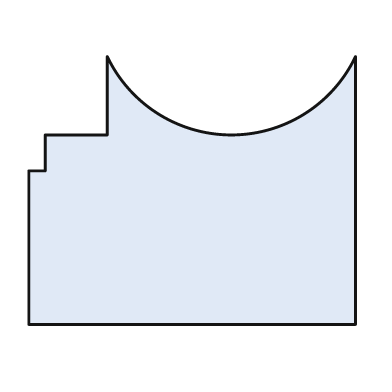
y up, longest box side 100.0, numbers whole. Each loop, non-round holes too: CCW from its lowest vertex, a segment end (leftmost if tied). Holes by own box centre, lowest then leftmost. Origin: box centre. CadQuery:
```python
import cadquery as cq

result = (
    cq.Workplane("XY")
    .moveTo(-50.0, -41.0)
    .lineTo(50.0, -41.0)
    .lineTo(50.0, 41.0)
    .threePointArc((12.0, 17.0), (-26.0, 41.0))
    .lineTo(-26.0, 17.0)
    .lineTo(-45.0, 17.0)
    .lineTo(-45.0, 6.0)
    .lineTo(-50.0, 6.0)
    .close()
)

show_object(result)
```